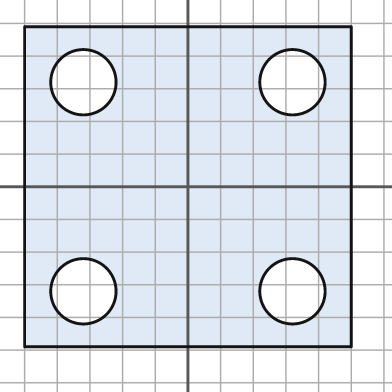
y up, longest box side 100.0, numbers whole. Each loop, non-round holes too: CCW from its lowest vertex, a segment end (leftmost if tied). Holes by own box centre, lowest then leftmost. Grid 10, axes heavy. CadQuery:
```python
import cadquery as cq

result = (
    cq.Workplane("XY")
    .moveTo(-50.0, -49.0)
    .lineTo(50.0, -49.0)
    .lineTo(50.0, 49.0)
    .lineTo(-50.0, 49.0)
    .close()
    .moveTo(-32.0, -32.0)
    .circle(10.0)
    .moveTo(32.0, -32.0)
    .circle(10.0)
    .moveTo(-32.0, 32.0)
    .circle(10.0)
    .moveTo(32.0, 32.0)
    .circle(10.0)
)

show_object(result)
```